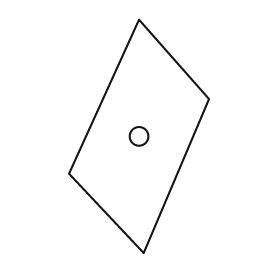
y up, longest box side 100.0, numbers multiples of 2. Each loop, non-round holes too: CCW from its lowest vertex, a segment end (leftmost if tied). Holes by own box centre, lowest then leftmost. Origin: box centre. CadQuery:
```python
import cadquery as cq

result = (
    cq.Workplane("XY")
    .moveTo(2.0, -50.0)
    .lineTo(30.0, 16.0)
    .lineTo(0.0, 50.0)
    .lineTo(-30.0, -16.0)
    .close()
    .moveTo(0.0, 0.0)
    .circle(4.0)
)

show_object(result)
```